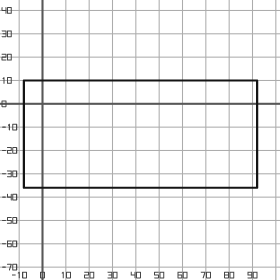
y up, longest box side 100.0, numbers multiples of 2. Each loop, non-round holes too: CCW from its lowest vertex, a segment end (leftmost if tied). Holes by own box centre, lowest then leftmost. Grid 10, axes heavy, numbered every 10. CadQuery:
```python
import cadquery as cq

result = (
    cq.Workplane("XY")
    .moveTo(-8.0, -36.0)
    .lineTo(92.0, -36.0)
    .lineTo(92.0, 10.0)
    .lineTo(-8.0, 10.0)
    .close()
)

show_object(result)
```